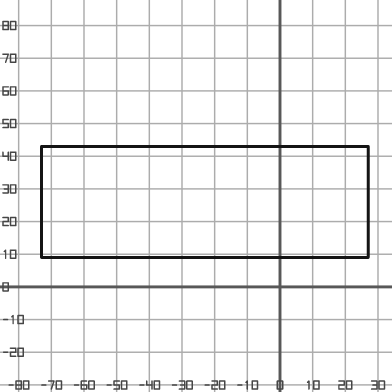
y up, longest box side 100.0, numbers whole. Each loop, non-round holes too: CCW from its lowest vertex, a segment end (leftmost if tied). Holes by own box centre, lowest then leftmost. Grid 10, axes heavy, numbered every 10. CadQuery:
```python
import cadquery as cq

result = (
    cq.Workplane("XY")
    .moveTo(-73.0, 9.0)
    .lineTo(27.0, 9.0)
    .lineTo(27.0, 43.0)
    .lineTo(-73.0, 43.0)
    .close()
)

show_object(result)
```